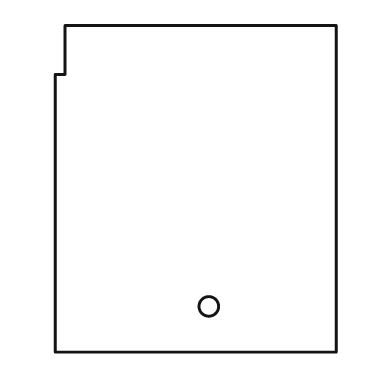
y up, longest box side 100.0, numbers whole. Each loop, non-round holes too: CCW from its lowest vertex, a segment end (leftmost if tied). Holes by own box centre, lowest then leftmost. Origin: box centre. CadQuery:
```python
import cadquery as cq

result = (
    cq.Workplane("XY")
    .moveTo(-43.0, -50.0)
    .lineTo(43.0, -50.0)
    .lineTo(43.0, 50.0)
    .lineTo(-40.0, 50.0)
    .lineTo(-40.0, 35.0)
    .lineTo(-43.0, 35.0)
    .close()
    .moveTo(4.0, -36.0)
    .circle(3.0)
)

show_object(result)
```